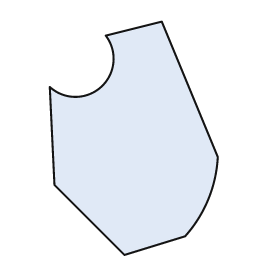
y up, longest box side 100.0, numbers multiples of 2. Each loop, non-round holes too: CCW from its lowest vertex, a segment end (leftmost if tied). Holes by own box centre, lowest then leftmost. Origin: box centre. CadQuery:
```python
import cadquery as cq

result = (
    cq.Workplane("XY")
    .moveTo(-4.0, -50.0)
    .lineTo(22.0, -42.0)
    .threePointArc((32.0, -26.0), (36.0, -8.0))
    .lineTo(12.0, 50.0)
    .lineTo(-12.0, 44.0)
    .threePointArc((-14.0, 22.0), (-36.0, 22.0))
    .lineTo(-34.0, -20.0)
    .close()
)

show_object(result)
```